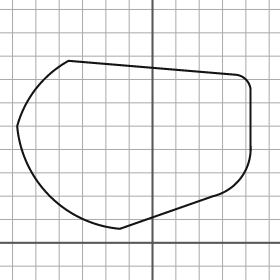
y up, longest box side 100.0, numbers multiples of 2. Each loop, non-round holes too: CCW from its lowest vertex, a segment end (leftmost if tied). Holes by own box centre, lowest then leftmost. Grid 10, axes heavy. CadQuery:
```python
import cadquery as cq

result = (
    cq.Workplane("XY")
    .moveTo(-14.0, 6.0)
    .lineTo(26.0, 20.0)
    .threePointArc((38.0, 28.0), (42.0, 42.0))
    .lineTo(42.0, 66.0)
    .threePointArc((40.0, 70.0), (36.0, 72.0))
    .lineTo(-36.0, 78.0)
    .threePointArc((-50.0, 66.0), (-58.0, 50.0))
    .threePointArc((-44.0, 20.0), (-14.0, 6.0))
    .close()
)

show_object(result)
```